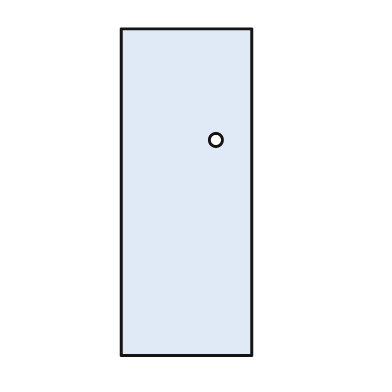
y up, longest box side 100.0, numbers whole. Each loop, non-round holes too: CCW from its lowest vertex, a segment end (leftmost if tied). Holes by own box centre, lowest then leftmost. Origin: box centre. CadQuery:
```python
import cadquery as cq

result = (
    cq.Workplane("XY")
    .moveTo(-20.0, -50.0)
    .lineTo(20.0, -50.0)
    .lineTo(20.0, 50.0)
    .lineTo(-20.0, 50.0)
    .close()
    .moveTo(9.0, 16.0)
    .circle(2.0)
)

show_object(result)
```